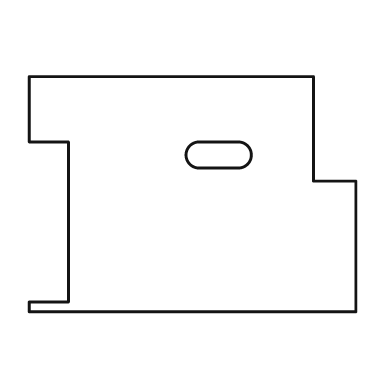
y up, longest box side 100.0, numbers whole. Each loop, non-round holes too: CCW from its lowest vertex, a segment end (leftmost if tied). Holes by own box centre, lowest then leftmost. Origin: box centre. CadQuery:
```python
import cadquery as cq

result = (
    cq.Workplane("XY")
    .moveTo(-50.0, -36.0)
    .lineTo(50.0, -36.0)
    .lineTo(50.0, 4.0)
    .lineTo(37.0, 4.0)
    .lineTo(37.0, 36.0)
    .lineTo(-50.0, 36.0)
    .lineTo(-50.0, 16.0)
    .lineTo(-38.0, 16.0)
    .lineTo(-38.0, -33.0)
    .lineTo(-50.0, -33.0)
    .close()
    .moveTo(2.0, 8.0)
    .lineTo(14.0, 8.0)
    .threePointArc((18.0, 12.0), (14.0, 16.0))
    .lineTo(2.0, 16.0)
    .threePointArc((-2.0, 12.0), (2.0, 8.0))
    .close()
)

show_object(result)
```